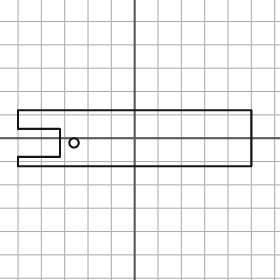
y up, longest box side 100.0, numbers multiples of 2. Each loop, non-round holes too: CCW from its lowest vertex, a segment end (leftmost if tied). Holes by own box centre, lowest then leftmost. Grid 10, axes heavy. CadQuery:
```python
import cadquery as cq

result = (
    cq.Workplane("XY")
    .moveTo(-50.0, -12.0)
    .lineTo(50.0, -12.0)
    .lineTo(50.0, 12.0)
    .lineTo(-50.0, 12.0)
    .lineTo(-50.0, 4.0)
    .lineTo(-32.0, 4.0)
    .lineTo(-32.0, -8.0)
    .lineTo(-50.0, -8.0)
    .close()
    .moveTo(-26.0, -2.0)
    .circle(2.0)
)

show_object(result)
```